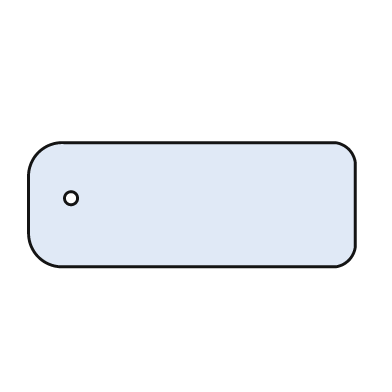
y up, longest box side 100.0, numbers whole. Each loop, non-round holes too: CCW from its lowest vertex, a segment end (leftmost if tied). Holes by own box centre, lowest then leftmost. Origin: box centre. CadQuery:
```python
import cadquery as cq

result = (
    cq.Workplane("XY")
    .moveTo(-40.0, -19.0)
    .lineTo(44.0, -19.0)
    .threePointArc((48.0, -17.0), (50.0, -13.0))
    .lineTo(50.0, 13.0)
    .threePointArc((48.0, 17.0), (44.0, 19.0))
    .lineTo(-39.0, 19.0)
    .threePointArc((-47.0, 16.0), (-50.0, 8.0))
    .lineTo(-50.0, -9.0)
    .threePointArc((-47.0, -16.0), (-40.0, -19.0))
    .close()
    .moveTo(-37.0, 2.0)
    .circle(2.0)
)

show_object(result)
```